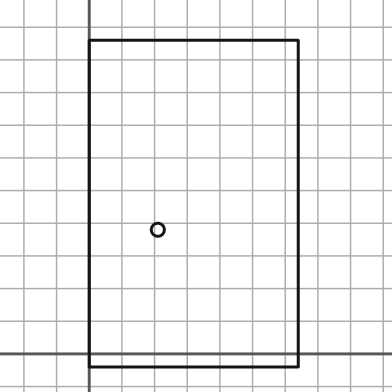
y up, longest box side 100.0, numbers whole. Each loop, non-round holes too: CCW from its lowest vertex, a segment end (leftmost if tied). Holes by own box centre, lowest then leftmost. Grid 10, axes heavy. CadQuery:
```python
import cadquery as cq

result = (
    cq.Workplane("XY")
    .moveTo(0.0, -4.0)
    .lineTo(64.0, -4.0)
    .lineTo(64.0, 96.0)
    .lineTo(0.0, 96.0)
    .close()
    .moveTo(21.0, 38.0)
    .circle(2.0)
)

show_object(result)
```